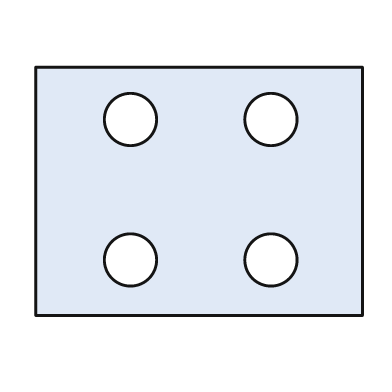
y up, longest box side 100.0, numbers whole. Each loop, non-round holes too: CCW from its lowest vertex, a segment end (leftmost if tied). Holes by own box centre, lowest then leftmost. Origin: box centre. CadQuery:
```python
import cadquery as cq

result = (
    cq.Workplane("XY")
    .moveTo(-50.0, -38.0)
    .lineTo(50.0, -38.0)
    .lineTo(50.0, 38.0)
    .lineTo(-50.0, 38.0)
    .close()
    .moveTo(-21.0, -21.0)
    .circle(8.0)
    .moveTo(22.0, -21.0)
    .circle(8.0)
    .moveTo(-21.0, 22.0)
    .circle(8.0)
    .moveTo(22.0, 22.0)
    .circle(8.0)
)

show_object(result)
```